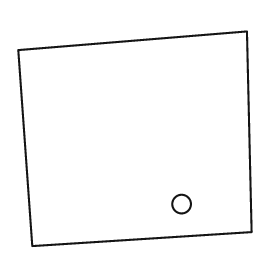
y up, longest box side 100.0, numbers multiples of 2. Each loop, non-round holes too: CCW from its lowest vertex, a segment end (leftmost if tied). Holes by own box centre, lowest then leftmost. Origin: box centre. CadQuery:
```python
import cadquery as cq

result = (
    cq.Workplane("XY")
    .moveTo(-44.0, -46.0)
    .lineTo(50.0, -40.0)
    .lineTo(48.0, 46.0)
    .lineTo(-50.0, 38.0)
    .close()
    .moveTo(20.0, -28.0)
    .circle(4.0)
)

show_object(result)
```